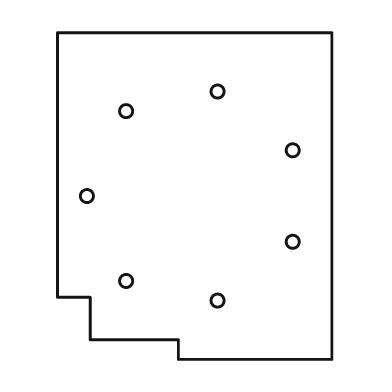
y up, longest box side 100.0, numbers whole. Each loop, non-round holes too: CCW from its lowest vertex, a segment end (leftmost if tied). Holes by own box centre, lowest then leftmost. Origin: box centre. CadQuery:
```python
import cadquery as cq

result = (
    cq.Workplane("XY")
    .moveTo(-5.0, -50.0)
    .lineTo(42.0, -50.0)
    .lineTo(42.0, 50.0)
    .lineTo(-42.0, 50.0)
    .lineTo(-42.0, -31.0)
    .lineTo(-32.0, -31.0)
    .lineTo(-32.0, -44.0)
    .lineTo(-5.0, -44.0)
    .close()
    .moveTo(7.0, -32.0)
    .circle(2.0)
    .moveTo(-21.0, -26.0)
    .circle(2.0)
    .moveTo(30.0, -14.0)
    .circle(2.0)
    .moveTo(-33.0, 0.0)
    .circle(2.0)
    .moveTo(30.0, 14.0)
    .circle(2.0)
    .moveTo(-21.0, 26.0)
    .circle(2.0)
    .moveTo(7.0, 32.0)
    .circle(2.0)
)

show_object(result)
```